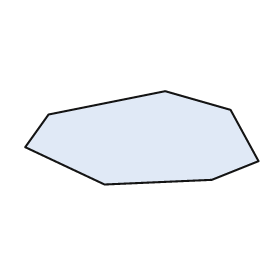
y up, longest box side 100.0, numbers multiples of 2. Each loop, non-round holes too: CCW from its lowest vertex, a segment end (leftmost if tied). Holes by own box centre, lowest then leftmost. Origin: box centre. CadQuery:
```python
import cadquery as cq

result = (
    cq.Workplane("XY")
    .moveTo(-16.0, -20.0)
    .lineTo(30.0, -18.0)
    .lineTo(50.0, -10.0)
    .lineTo(38.0, 12.0)
    .lineTo(10.0, 20.0)
    .lineTo(-40.0, 10.0)
    .lineTo(-50.0, -4.0)
    .close()
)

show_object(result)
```